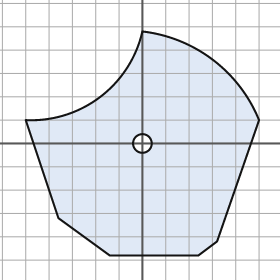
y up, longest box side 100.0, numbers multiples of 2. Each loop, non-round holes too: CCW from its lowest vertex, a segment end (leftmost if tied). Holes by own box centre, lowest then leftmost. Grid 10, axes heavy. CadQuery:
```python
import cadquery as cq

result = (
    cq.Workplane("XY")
    .moveTo(-14.0, -48.0)
    .lineTo(24.0, -48.0)
    .lineTo(32.0, -42.0)
    .lineTo(50.0, 10.0)
    .threePointArc((30.0, 36.0), (0.0, 48.0))
    .threePointArc((-18.0, 20.0), (-50.0, 10.0))
    .lineTo(-36.0, -32.0)
    .close()
    .moveTo(0.0, 0.0)
    .circle(4.0)
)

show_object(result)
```